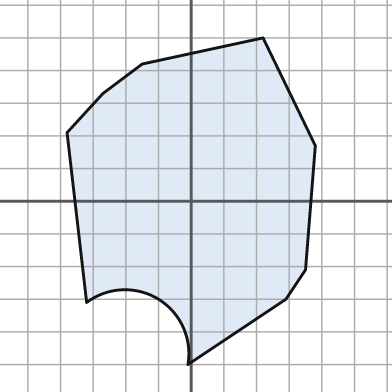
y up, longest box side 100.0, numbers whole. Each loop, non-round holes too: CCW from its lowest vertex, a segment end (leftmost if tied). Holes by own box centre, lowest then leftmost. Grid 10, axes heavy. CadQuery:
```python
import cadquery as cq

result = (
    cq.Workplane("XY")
    .moveTo(-1.0, -50.0)
    .lineTo(29.0, -30.0)
    .lineTo(35.0, -21.0)
    .lineTo(38.0, 17.0)
    .lineTo(22.0, 50.0)
    .lineTo(-15.0, 42.0)
    .lineTo(-27.0, 33.0)
    .lineTo(-38.0, 21.0)
    .lineTo(-32.0, -31.0)
    .threePointArc((-10.0, -30.0), (-1.0, -50.0))
    .close()
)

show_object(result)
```